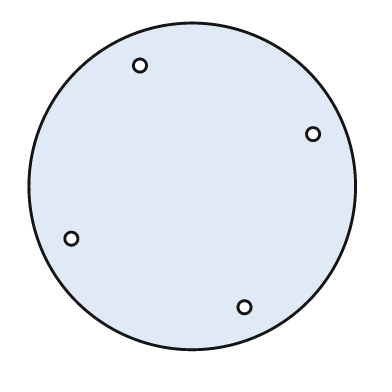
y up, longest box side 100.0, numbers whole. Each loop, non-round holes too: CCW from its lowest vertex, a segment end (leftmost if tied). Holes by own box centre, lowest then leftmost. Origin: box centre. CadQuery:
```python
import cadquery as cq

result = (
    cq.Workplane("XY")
    .moveTo(0.0, 0.0)
    .circle(50.0)
    .moveTo(16.0, -37.0)
    .circle(2.0)
    .moveTo(-37.0, -16.0)
    .circle(2.0)
    .moveTo(37.0, 16.0)
    .circle(2.0)
    .moveTo(-16.0, 37.0)
    .circle(2.0)
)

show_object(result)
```